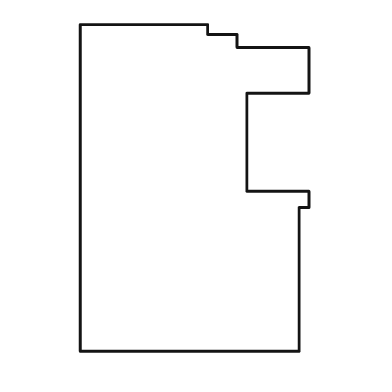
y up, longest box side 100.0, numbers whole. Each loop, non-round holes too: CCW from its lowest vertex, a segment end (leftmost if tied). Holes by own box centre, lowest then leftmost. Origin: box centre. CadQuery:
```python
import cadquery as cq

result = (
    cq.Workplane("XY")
    .moveTo(-35.0, -50.0)
    .lineTo(32.0, -50.0)
    .lineTo(32.0, -6.0)
    .lineTo(35.0, -6.0)
    .lineTo(35.0, -1.0)
    .lineTo(16.0, -1.0)
    .lineTo(16.0, 29.0)
    .lineTo(35.0, 29.0)
    .lineTo(35.0, 43.0)
    .lineTo(13.0, 43.0)
    .lineTo(13.0, 47.0)
    .lineTo(4.0, 47.0)
    .lineTo(4.0, 50.0)
    .lineTo(-35.0, 50.0)
    .close()
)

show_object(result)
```